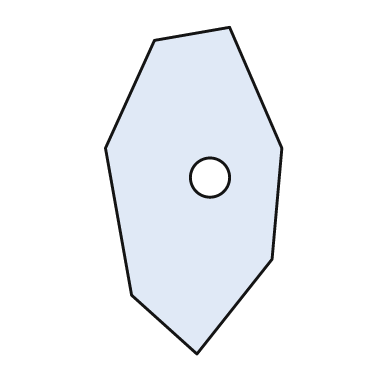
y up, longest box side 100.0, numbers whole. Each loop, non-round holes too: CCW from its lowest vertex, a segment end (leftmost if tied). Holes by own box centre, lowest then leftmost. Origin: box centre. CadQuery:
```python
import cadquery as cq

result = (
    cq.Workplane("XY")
    .moveTo(1.0, -50.0)
    .lineTo(24.0, -21.0)
    .lineTo(27.0, 13.0)
    .lineTo(11.0, 50.0)
    .lineTo(-12.0, 46.0)
    .lineTo(-27.0, 13.0)
    .lineTo(-19.0, -32.0)
    .close()
    .moveTo(5.0, 4.0)
    .circle(6.0)
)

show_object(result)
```